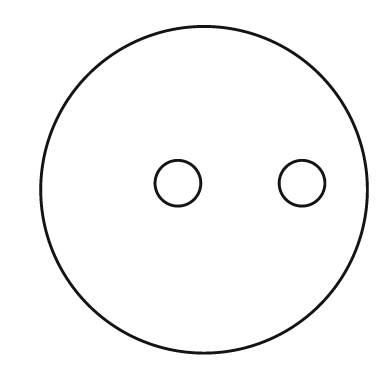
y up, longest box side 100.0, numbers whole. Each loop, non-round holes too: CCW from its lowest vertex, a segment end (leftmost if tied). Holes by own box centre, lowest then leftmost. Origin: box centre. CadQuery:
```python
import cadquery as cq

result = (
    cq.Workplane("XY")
    .moveTo(0.0, 0.0)
    .circle(50.0)
    .moveTo(-8.0, 2.0)
    .circle(7.0)
    .moveTo(30.0, 2.0)
    .circle(7.0)
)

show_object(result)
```